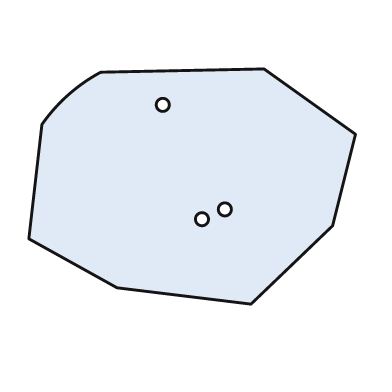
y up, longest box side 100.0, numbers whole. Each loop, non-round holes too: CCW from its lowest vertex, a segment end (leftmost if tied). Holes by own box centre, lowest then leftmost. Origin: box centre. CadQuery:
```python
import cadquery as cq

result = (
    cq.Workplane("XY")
    .moveTo(18.0, -36.0)
    .lineTo(43.0, -12.0)
    .lineTo(50.0, 16.0)
    .lineTo(22.0, 36.0)
    .lineTo(-28.0, 35.0)
    .threePointArc((-38.0, 28.0), (-46.0, 19.0))
    .lineTo(-50.0, -16.0)
    .lineTo(-23.0, -31.0)
    .close()
    .moveTo(3.0, -10.0)
    .circle(2.0)
    .moveTo(10.0, -7.0)
    .circle(2.0)
    .moveTo(-9.0, 25.0)
    .circle(2.0)
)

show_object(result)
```